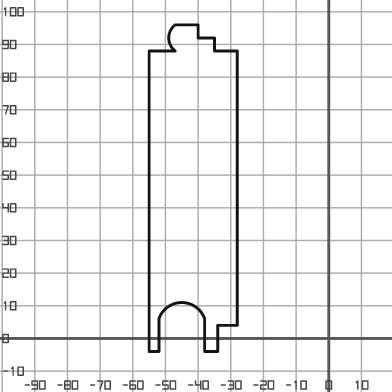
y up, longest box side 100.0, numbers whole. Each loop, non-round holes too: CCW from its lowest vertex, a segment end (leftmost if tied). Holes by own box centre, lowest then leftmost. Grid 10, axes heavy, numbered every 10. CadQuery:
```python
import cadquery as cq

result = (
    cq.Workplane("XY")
    .moveTo(-55.0, -4.0)
    .lineTo(-52.0, -4.0)
    .lineTo(-52.0, 6.0)
    .threePointArc((-45.0, 11.0), (-38.0, 6.0))
    .lineTo(-38.0, -4.0)
    .lineTo(-34.0, -4.0)
    .lineTo(-34.0, 4.0)
    .lineTo(-28.0, 4.0)
    .lineTo(-28.0, 88.0)
    .lineTo(-35.0, 88.0)
    .lineTo(-35.0, 92.0)
    .lineTo(-40.0, 92.0)
    .lineTo(-40.0, 96.0)
    .lineTo(-47.0, 96.0)
    .threePointArc((-49.0, 92.0), (-47.0, 88.0))
    .lineTo(-55.0, 88.0)
    .close()
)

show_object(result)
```